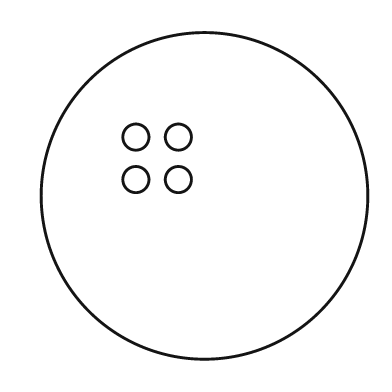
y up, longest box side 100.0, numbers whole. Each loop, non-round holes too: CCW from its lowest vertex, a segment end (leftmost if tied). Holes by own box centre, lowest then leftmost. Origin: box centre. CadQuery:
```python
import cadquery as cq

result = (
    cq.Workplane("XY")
    .moveTo(0.0, 0.0)
    .circle(50.0)
    .moveTo(-21.0, 5.0)
    .circle(4.0)
    .moveTo(-8.0, 5.0)
    .circle(4.0)
    .moveTo(-21.0, 18.0)
    .circle(4.0)
    .moveTo(-8.0, 18.0)
    .circle(4.0)
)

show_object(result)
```